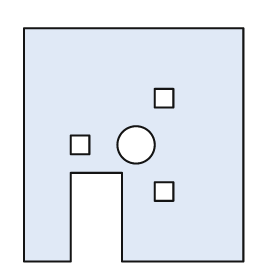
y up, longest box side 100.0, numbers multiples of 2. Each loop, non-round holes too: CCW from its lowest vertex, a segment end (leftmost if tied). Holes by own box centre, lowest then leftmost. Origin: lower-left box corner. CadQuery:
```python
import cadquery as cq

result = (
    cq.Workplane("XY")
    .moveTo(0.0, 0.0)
    .lineTo(20.0, 0.0)
    .lineTo(20.0, 38.0)
    .lineTo(42.0, 38.0)
    .lineTo(42.0, 0.0)
    .lineTo(94.0, 0.0)
    .lineTo(94.0, 100.0)
    .lineTo(0.0, 100.0)
    .close()
    .moveTo(56.0, 26.0)
    .lineTo(64.0, 26.0)
    .lineTo(64.0, 34.0)
    .lineTo(56.0, 34.0)
    .close()
    .moveTo(20.0, 46.0)
    .lineTo(28.0, 46.0)
    .lineTo(28.0, 54.0)
    .lineTo(20.0, 54.0)
    .close()
    .moveTo(48.0, 50.0)
    .circle(8.0)
    .moveTo(56.0, 66.0)
    .lineTo(64.0, 66.0)
    .lineTo(64.0, 74.0)
    .lineTo(56.0, 74.0)
    .close()
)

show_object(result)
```